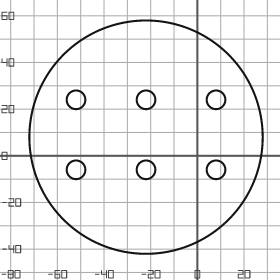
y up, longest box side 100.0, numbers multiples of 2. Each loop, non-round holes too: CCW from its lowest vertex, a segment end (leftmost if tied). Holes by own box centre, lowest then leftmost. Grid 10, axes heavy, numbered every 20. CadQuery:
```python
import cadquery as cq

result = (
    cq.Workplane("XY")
    .moveTo(-22.0, 8.0)
    .circle(50.0)
    .moveTo(-52.0, -6.0)
    .circle(4.0)
    .moveTo(-22.0, -6.0)
    .circle(4.0)
    .moveTo(8.0, -6.0)
    .circle(4.0)
    .moveTo(-52.0, 24.0)
    .circle(4.0)
    .moveTo(-22.0, 24.0)
    .circle(4.0)
    .moveTo(8.0, 24.0)
    .circle(4.0)
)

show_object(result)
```